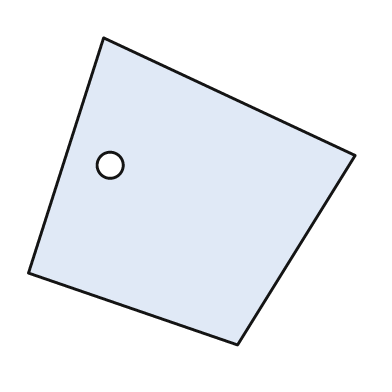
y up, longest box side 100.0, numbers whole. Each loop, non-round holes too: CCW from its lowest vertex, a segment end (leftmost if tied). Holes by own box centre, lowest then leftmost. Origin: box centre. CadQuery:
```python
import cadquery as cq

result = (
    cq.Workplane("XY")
    .moveTo(14.0, -47.0)
    .lineTo(50.0, 11.0)
    .lineTo(-27.0, 47.0)
    .lineTo(-50.0, -25.0)
    .close()
    .moveTo(-25.0, 8.0)
    .circle(4.0)
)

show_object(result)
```